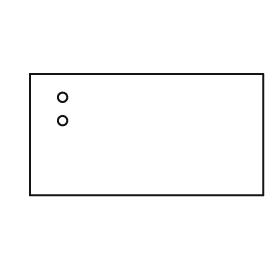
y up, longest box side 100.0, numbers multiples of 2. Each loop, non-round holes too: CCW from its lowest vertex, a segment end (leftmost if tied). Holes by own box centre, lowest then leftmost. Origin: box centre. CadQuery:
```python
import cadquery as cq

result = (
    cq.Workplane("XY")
    .moveTo(-50.0, -26.0)
    .lineTo(50.0, -26.0)
    .lineTo(50.0, 26.0)
    .lineTo(-50.0, 26.0)
    .close()
    .moveTo(-36.0, 6.0)
    .circle(2.0)
    .moveTo(-36.0, 16.0)
    .circle(2.0)
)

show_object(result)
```